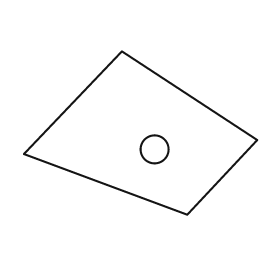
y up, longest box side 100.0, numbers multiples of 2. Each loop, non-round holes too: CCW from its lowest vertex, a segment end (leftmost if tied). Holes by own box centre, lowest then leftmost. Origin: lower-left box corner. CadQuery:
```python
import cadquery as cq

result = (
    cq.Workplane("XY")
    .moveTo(70.0, 0.0)
    .lineTo(100.0, 32.0)
    .lineTo(42.0, 70.0)
    .lineTo(0.0, 26.0)
    .close()
    .moveTo(56.0, 28.0)
    .circle(6.0)
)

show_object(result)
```